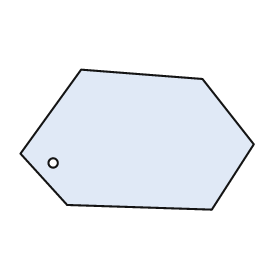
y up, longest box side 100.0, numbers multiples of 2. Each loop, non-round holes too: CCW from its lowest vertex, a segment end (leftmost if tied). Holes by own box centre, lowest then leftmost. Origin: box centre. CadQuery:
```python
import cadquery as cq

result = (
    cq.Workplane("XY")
    .moveTo(32.0, -30.0)
    .lineTo(50.0, -2.0)
    .lineTo(28.0, 26.0)
    .lineTo(-24.0, 30.0)
    .lineTo(-50.0, -6.0)
    .lineTo(-30.0, -28.0)
    .close()
    .moveTo(-36.0, -10.0)
    .circle(2.0)
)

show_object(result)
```